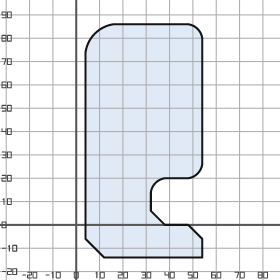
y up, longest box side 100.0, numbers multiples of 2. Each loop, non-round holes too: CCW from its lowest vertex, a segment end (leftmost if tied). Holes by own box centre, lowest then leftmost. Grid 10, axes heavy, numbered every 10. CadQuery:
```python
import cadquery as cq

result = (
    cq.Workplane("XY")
    .moveTo(12.0, -14.0)
    .lineTo(54.0, -14.0)
    .lineTo(54.0, -6.0)
    .lineTo(48.0, 0.0)
    .lineTo(38.0, 0.0)
    .lineTo(32.0, 6.0)
    .lineTo(32.0, 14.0)
    .threePointArc((34.0, 18.0), (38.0, 20.0))
    .lineTo(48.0, 20.0)
    .threePointArc((52.0, 22.0), (54.0, 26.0))
    .lineTo(54.0, 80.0)
    .threePointArc((52.0, 84.0), (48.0, 86.0))
    .lineTo(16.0, 86.0)
    .threePointArc((8.0, 82.0), (4.0, 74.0))
    .lineTo(4.0, -6.0)
    .close()
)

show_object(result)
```